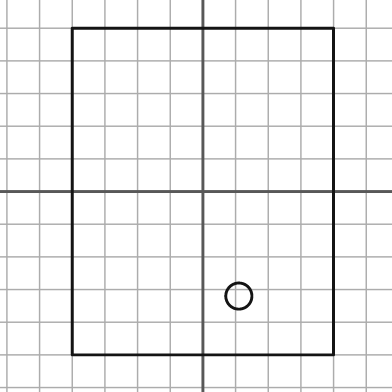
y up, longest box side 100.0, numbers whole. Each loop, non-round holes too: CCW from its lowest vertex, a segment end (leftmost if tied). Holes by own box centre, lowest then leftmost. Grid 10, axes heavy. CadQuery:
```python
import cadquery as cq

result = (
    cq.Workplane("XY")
    .moveTo(-40.0, -50.0)
    .lineTo(40.0, -50.0)
    .lineTo(40.0, 50.0)
    .lineTo(-40.0, 50.0)
    .close()
    .moveTo(11.0, -32.0)
    .circle(4.0)
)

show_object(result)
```